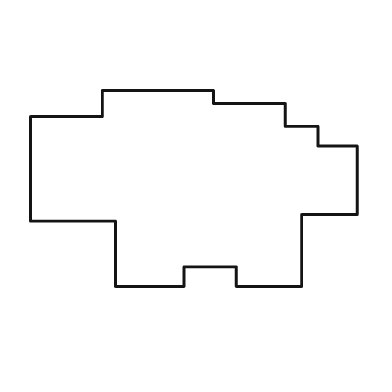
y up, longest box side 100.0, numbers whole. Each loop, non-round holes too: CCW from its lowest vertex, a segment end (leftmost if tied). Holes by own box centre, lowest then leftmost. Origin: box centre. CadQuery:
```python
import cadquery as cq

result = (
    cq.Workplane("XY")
    .moveTo(-24.0, -30.0)
    .lineTo(-3.0, -30.0)
    .lineTo(-3.0, -24.0)
    .lineTo(13.0, -24.0)
    .lineTo(13.0, -30.0)
    .lineTo(33.0, -30.0)
    .lineTo(33.0, -8.0)
    .lineTo(50.0, -8.0)
    .lineTo(50.0, 13.0)
    .lineTo(38.0, 13.0)
    .lineTo(38.0, 19.0)
    .lineTo(28.0, 19.0)
    .lineTo(28.0, 26.0)
    .lineTo(6.0, 26.0)
    .lineTo(6.0, 30.0)
    .lineTo(-28.0, 30.0)
    .lineTo(-28.0, 22.0)
    .lineTo(-50.0, 22.0)
    .lineTo(-50.0, -10.0)
    .lineTo(-24.0, -10.0)
    .close()
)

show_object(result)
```